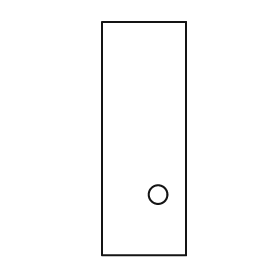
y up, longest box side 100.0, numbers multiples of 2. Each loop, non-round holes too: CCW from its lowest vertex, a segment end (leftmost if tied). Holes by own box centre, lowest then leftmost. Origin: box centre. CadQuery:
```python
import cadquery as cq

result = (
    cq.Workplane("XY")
    .moveTo(-18.0, -50.0)
    .lineTo(18.0, -50.0)
    .lineTo(18.0, 50.0)
    .lineTo(-18.0, 50.0)
    .close()
    .moveTo(6.0, -24.0)
    .circle(4.0)
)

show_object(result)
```